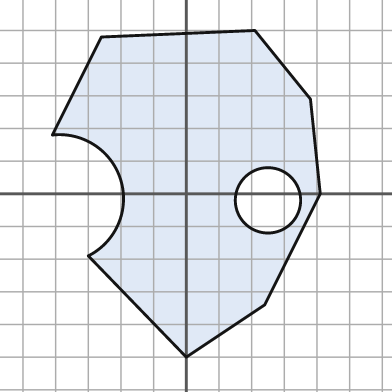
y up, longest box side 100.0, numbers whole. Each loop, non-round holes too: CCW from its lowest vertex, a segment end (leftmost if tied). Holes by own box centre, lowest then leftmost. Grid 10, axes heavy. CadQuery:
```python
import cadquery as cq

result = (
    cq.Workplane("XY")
    .moveTo(0.0, -50.0)
    .lineTo(24.0, -34.0)
    .lineTo(41.0, 0.0)
    .lineTo(38.0, 29.0)
    .lineTo(21.0, 50.0)
    .lineTo(-26.0, 48.0)
    .lineTo(-41.0, 18.0)
    .threePointArc((-20.0, 4.0), (-30.0, -19.0))
    .close()
    .moveTo(25.0, -2.0)
    .circle(10.0)
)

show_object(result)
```